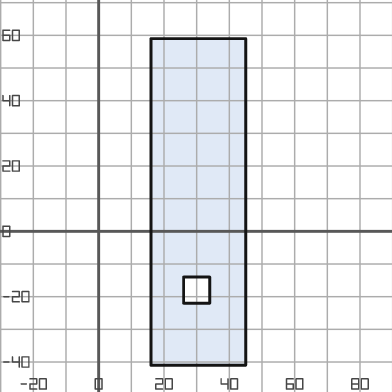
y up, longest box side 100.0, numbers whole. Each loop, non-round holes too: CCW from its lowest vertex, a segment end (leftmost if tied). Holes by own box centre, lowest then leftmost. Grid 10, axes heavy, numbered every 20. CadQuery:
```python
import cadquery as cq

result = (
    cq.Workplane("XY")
    .moveTo(16.0, -41.0)
    .lineTo(45.0, -41.0)
    .lineTo(45.0, 59.0)
    .lineTo(16.0, 59.0)
    .close()
    .moveTo(26.0, -22.0)
    .lineTo(34.0, -22.0)
    .lineTo(34.0, -14.0)
    .lineTo(26.0, -14.0)
    .close()
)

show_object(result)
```